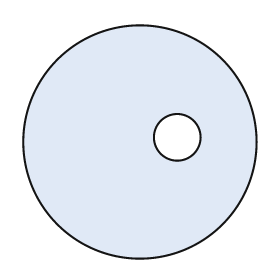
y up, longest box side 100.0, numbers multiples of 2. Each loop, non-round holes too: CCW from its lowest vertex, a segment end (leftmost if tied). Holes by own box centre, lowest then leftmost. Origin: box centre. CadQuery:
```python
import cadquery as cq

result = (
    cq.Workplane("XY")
    .moveTo(0.0, 0.0)
    .circle(50.0)
    .moveTo(16.0, 2.0)
    .circle(10.0)
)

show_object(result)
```